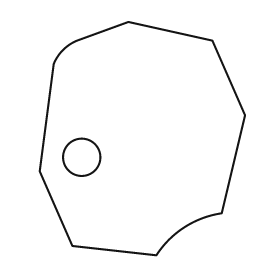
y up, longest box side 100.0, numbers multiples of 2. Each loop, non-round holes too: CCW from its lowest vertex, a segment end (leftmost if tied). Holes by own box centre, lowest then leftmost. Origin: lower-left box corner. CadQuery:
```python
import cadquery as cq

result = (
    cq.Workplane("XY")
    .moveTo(50.0, 0.0)
    .threePointArc((62.0, 12.0), (78.0, 18.0))
    .lineTo(88.0, 60.0)
    .lineTo(74.0, 92.0)
    .lineTo(38.0, 100.0)
    .lineTo(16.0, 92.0)
    .threePointArc((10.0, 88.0), (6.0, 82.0))
    .lineTo(0.0, 36.0)
    .lineTo(14.0, 4.0)
    .close()
    .moveTo(18.0, 42.0)
    .circle(8.0)
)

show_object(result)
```